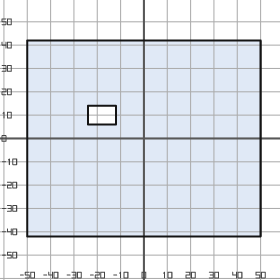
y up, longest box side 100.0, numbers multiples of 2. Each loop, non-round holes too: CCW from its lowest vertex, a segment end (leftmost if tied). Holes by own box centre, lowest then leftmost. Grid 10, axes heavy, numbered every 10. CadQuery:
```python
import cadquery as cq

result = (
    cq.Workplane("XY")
    .moveTo(-50.0, -42.0)
    .lineTo(50.0, -42.0)
    .lineTo(50.0, 42.0)
    .lineTo(-50.0, 42.0)
    .close()
    .moveTo(-24.0, 6.0)
    .lineTo(-12.0, 6.0)
    .lineTo(-12.0, 14.0)
    .lineTo(-24.0, 14.0)
    .close()
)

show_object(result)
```